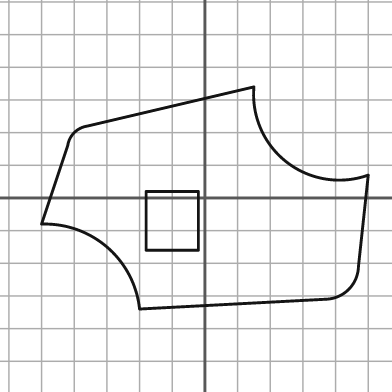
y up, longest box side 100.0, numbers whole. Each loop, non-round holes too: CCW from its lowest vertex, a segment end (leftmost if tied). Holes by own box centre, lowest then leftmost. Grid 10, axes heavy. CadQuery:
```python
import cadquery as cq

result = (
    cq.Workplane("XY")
    .moveTo(-20.0, -34.0)
    .lineTo(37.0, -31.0)
    .threePointArc((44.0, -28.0), (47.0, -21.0))
    .lineTo(50.0, 7.0)
    .threePointArc((25.0, 11.0), (15.0, 34.0))
    .lineTo(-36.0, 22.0)
    .threePointArc((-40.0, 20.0), (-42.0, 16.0))
    .lineTo(-50.0, -8.0)
    .threePointArc((-30.0, -15.0), (-20.0, -34.0))
    .close()
    .moveTo(-18.0, -16.0)
    .lineTo(-2.0, -16.0)
    .lineTo(-2.0, 2.0)
    .lineTo(-18.0, 2.0)
    .close()
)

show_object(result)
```